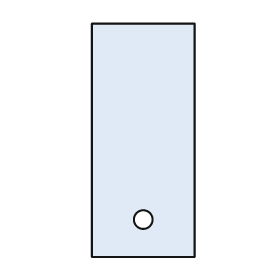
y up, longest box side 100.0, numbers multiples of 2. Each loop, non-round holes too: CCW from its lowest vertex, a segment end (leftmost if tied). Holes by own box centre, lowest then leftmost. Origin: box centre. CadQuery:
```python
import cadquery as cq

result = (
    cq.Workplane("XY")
    .moveTo(-22.0, -50.0)
    .lineTo(22.0, -50.0)
    .lineTo(22.0, 50.0)
    .lineTo(-22.0, 50.0)
    .close()
    .moveTo(0.0, -34.0)
    .circle(4.0)
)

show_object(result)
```